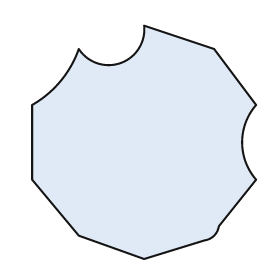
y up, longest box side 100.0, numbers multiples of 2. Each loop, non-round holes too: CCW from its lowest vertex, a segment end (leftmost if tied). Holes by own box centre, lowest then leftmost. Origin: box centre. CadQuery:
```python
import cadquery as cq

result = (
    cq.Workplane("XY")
    .moveTo(0.0, -50.0)
    .lineTo(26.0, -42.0)
    .threePointArc((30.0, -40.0), (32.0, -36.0))
    .lineTo(48.0, -16.0)
    .threePointArc((42.0, 0.0), (48.0, 16.0))
    .lineTo(30.0, 40.0)
    .lineTo(0.0, 50.0)
    .threePointArc((-10.0, 34.0), (-28.0, 40.0))
    .threePointArc((-36.0, 26.0), (-48.0, 16.0))
    .lineTo(-48.0, -16.0)
    .lineTo(-28.0, -40.0)
    .close()
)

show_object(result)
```